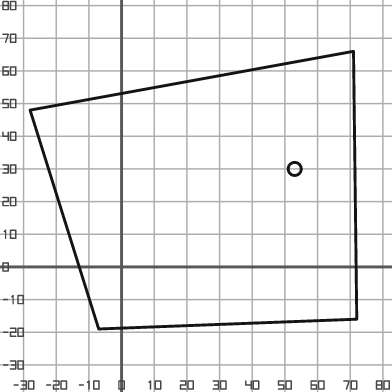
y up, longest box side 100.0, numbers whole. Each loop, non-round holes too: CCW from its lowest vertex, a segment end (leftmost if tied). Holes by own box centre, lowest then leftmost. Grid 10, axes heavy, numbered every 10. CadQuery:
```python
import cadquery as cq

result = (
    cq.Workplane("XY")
    .moveTo(-7.0, -19.0)
    .lineTo(72.0, -16.0)
    .lineTo(71.0, 66.0)
    .lineTo(-28.0, 48.0)
    .close()
    .moveTo(53.0, 30.0)
    .circle(2.0)
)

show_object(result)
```